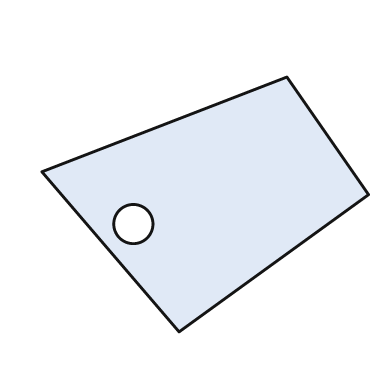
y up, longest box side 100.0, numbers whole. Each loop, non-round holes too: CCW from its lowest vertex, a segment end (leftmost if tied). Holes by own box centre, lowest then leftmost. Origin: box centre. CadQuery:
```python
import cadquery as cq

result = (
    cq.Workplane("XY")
    .moveTo(-8.0, -39.0)
    .lineTo(50.0, 3.0)
    .lineTo(25.0, 39.0)
    .lineTo(-50.0, 10.0)
    .close()
    .moveTo(-22.0, -6.0)
    .circle(6.0)
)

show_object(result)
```